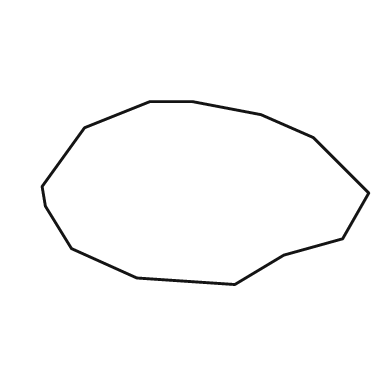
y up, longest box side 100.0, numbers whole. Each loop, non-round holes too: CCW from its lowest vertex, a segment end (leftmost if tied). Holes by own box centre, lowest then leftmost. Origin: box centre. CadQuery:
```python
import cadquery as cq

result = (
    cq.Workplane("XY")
    .moveTo(9.0, -28.0)
    .lineTo(24.0, -19.0)
    .lineTo(42.0, -14.0)
    .lineTo(50.0, 0.0)
    .lineTo(33.0, 17.0)
    .lineTo(17.0, 24.0)
    .lineTo(-4.0, 28.0)
    .lineTo(-17.0, 28.0)
    .lineTo(-37.0, 20.0)
    .lineTo(-50.0, 2.0)
    .lineTo(-49.0, -4.0)
    .lineTo(-41.0, -17.0)
    .lineTo(-21.0, -26.0)
    .close()
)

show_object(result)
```